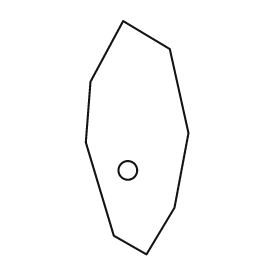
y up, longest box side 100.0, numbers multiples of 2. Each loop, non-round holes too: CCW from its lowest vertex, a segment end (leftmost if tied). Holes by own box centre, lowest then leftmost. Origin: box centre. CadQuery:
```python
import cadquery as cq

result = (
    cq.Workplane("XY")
    .moveTo(4.0, -50.0)
    .lineTo(16.0, -30.0)
    .lineTo(22.0, 2.0)
    .lineTo(14.0, 38.0)
    .lineTo(-6.0, 50.0)
    .lineTo(-20.0, 24.0)
    .lineTo(-22.0, -2.0)
    .lineTo(-10.0, -42.0)
    .close()
    .moveTo(-4.0, -14.0)
    .circle(4.0)
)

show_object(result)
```